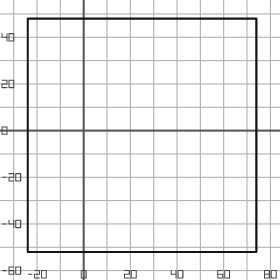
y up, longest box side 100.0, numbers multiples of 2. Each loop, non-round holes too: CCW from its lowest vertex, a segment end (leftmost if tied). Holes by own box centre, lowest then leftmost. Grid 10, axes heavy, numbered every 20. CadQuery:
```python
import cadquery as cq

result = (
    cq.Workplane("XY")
    .moveTo(-24.0, -52.0)
    .lineTo(74.0, -52.0)
    .lineTo(74.0, 48.0)
    .lineTo(-24.0, 48.0)
    .close()
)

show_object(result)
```